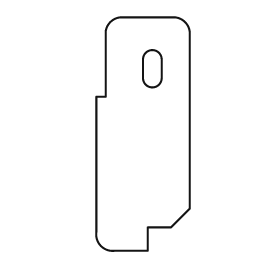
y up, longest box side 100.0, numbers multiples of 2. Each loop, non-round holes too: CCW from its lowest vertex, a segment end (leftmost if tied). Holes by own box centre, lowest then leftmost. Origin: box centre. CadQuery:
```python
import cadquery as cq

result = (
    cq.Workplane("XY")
    .moveTo(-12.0, -50.0)
    .lineTo(2.0, -50.0)
    .lineTo(2.0, -40.0)
    .lineTo(12.0, -40.0)
    .lineTo(20.0, -32.0)
    .lineTo(20.0, 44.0)
    .threePointArc((18.0, 48.0), (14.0, 50.0))
    .lineTo(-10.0, 50.0)
    .threePointArc((-14.0, 48.0), (-16.0, 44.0))
    .lineTo(-16.0, 16.0)
    .lineTo(-20.0, 16.0)
    .lineTo(-20.0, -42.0)
    .threePointArc((-18.0, -48.0), (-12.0, -50.0))
    .close()
    .moveTo(0.0, 24.0)
    .threePointArc((4.0, 20.0), (8.0, 24.0))
    .lineTo(8.0, 32.0)
    .threePointArc((4.0, 36.0), (0.0, 32.0))
    .close()
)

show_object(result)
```